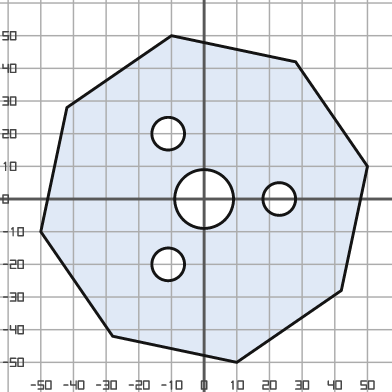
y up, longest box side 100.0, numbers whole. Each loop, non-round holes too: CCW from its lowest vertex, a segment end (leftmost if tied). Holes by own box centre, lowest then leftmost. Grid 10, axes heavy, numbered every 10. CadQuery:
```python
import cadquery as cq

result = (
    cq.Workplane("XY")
    .moveTo(10.0, -50.0)
    .lineTo(42.0, -28.0)
    .lineTo(50.0, 10.0)
    .lineTo(28.0, 42.0)
    .lineTo(-10.0, 50.0)
    .lineTo(-42.0, 28.0)
    .lineTo(-50.0, -10.0)
    .lineTo(-28.0, -42.0)
    .close()
    .moveTo(-11.0, -20.0)
    .circle(5.0)
    .moveTo(0.0, 0.0)
    .circle(9.0)
    .moveTo(23.0, 0.0)
    .circle(5.0)
    .moveTo(-11.0, 20.0)
    .circle(5.0)
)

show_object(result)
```